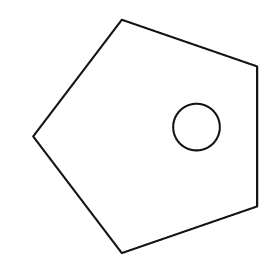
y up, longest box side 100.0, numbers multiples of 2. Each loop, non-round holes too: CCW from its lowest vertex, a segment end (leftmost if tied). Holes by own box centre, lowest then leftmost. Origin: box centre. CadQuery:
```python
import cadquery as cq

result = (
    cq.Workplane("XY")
    .moveTo(-10.0, -50.0)
    .lineTo(48.0, -30.0)
    .lineTo(48.0, 30.0)
    .lineTo(-10.0, 50.0)
    .lineTo(-48.0, 0.0)
    .close()
    .moveTo(22.0, 4.0)
    .circle(10.0)
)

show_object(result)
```